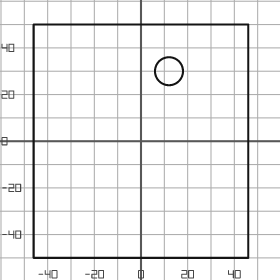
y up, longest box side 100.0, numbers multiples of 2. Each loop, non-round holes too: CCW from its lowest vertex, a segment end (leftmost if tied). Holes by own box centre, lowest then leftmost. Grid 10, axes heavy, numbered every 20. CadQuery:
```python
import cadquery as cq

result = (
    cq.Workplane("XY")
    .moveTo(-46.0, -50.0)
    .lineTo(46.0, -50.0)
    .lineTo(46.0, 50.0)
    .lineTo(-46.0, 50.0)
    .close()
    .moveTo(12.0, 30.0)
    .circle(6.0)
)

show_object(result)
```